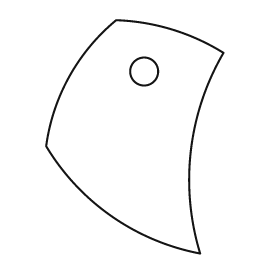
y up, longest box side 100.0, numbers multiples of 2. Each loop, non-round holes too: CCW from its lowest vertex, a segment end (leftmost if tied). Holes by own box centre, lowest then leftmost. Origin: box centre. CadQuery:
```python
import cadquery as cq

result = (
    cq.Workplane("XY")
    .moveTo(28.0, -50.0)
    .threePointArc((24.0, -6.0), (38.0, 36.0))
    .threePointArc((16.0, 46.0), (-8.0, 50.0))
    .threePointArc((-28.0, 26.0), (-38.0, -4.0))
    .threePointArc((-10.0, -34.0), (28.0, -50.0))
    .close()
    .moveTo(4.0, 28.0)
    .circle(6.0)
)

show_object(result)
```